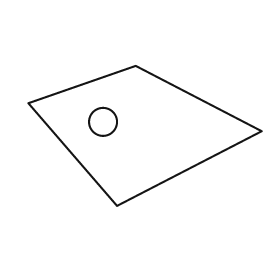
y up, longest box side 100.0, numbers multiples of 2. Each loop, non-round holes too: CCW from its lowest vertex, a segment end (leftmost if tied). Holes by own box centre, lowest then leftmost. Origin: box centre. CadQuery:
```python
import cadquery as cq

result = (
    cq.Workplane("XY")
    .moveTo(-12.0, -30.0)
    .lineTo(50.0, 2.0)
    .lineTo(-4.0, 30.0)
    .lineTo(-50.0, 14.0)
    .close()
    .moveTo(-18.0, 6.0)
    .circle(6.0)
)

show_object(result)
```